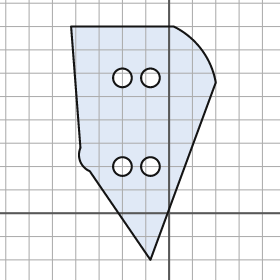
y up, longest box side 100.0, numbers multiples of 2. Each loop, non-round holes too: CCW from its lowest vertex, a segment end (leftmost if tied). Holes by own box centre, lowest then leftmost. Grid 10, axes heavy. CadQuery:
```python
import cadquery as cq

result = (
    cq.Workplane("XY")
    .moveTo(-8.0, -20.0)
    .lineTo(20.0, 56.0)
    .threePointArc((14.0, 70.0), (2.0, 80.0))
    .lineTo(-42.0, 80.0)
    .lineTo(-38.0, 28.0)
    .threePointArc((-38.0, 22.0), (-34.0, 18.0))
    .close()
    .moveTo(-20.0, 20.0)
    .circle(4.0)
    .moveTo(-8.0, 20.0)
    .circle(4.0)
    .moveTo(-20.0, 58.0)
    .circle(4.0)
    .moveTo(-8.0, 58.0)
    .circle(4.0)
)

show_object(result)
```